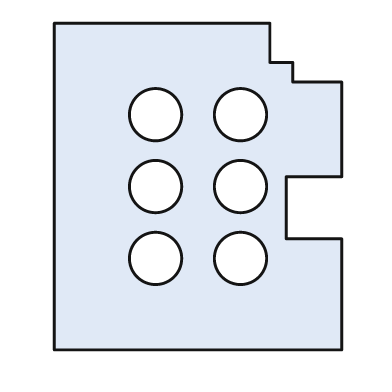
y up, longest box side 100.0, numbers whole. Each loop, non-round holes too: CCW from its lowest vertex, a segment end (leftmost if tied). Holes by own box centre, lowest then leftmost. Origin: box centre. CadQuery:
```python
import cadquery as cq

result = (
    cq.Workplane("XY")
    .moveTo(-44.0, -50.0)
    .lineTo(44.0, -50.0)
    .lineTo(44.0, -16.0)
    .lineTo(27.0, -16.0)
    .lineTo(27.0, 3.0)
    .lineTo(44.0, 3.0)
    .lineTo(44.0, 32.0)
    .lineTo(29.0, 32.0)
    .lineTo(29.0, 38.0)
    .lineTo(22.0, 38.0)
    .lineTo(22.0, 50.0)
    .lineTo(-44.0, 50.0)
    .close()
    .moveTo(-13.0, -22.0)
    .circle(8.0)
    .moveTo(13.0, -22.0)
    .circle(8.0)
    .moveTo(-13.0, 0.0)
    .circle(8.0)
    .moveTo(13.0, 0.0)
    .circle(8.0)
    .moveTo(-13.0, 22.0)
    .circle(8.0)
    .moveTo(13.0, 22.0)
    .circle(8.0)
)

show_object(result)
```